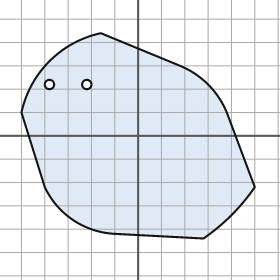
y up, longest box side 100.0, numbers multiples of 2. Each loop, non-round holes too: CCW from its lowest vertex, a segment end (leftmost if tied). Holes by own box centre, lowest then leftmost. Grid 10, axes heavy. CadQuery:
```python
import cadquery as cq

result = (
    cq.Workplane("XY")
    .moveTo(28.0, -44.0)
    .threePointArc((40.0, -34.0), (50.0, -22.0))
    .lineTo(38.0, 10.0)
    .threePointArc((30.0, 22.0), (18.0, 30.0))
    .lineTo(-16.0, 44.0)
    .threePointArc((-38.0, 32.0), (-50.0, 10.0))
    .lineTo(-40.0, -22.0)
    .threePointArc((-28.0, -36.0), (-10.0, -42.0))
    .close()
    .moveTo(-38.0, 22.0)
    .circle(2.0)
    .moveTo(-22.0, 22.0)
    .circle(2.0)
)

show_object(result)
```